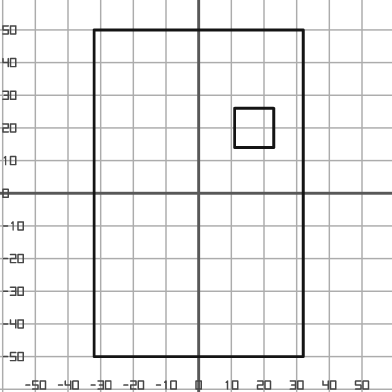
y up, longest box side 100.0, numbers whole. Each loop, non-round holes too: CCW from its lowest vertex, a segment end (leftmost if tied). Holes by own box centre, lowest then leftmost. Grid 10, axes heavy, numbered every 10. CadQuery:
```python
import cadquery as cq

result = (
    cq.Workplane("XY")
    .moveTo(-32.0, -50.0)
    .lineTo(32.0, -50.0)
    .lineTo(32.0, 50.0)
    .lineTo(-32.0, 50.0)
    .close()
    .moveTo(11.0, 14.0)
    .lineTo(23.0, 14.0)
    .lineTo(23.0, 26.0)
    .lineTo(11.0, 26.0)
    .close()
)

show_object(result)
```